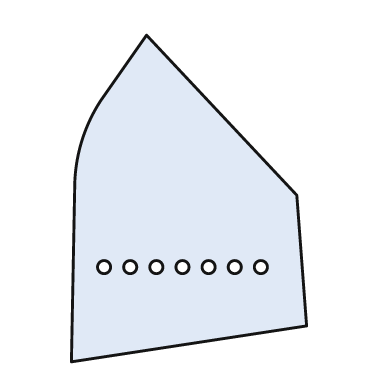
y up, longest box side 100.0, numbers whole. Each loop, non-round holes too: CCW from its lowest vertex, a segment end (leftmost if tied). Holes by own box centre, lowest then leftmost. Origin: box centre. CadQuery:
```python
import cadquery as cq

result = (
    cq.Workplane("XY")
    .moveTo(-36.0, -50.0)
    .lineTo(36.0, -39.0)
    .lineTo(33.0, 1.0)
    .lineTo(-13.0, 50.0)
    .lineTo(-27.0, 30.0)
    .threePointArc((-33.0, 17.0), (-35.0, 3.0))
    .close()
    .moveTo(-26.0, -21.0)
    .circle(2.0)
    .moveTo(-18.0, -21.0)
    .circle(2.0)
    .moveTo(-10.0, -21.0)
    .circle(2.0)
    .moveTo(-2.0, -21.0)
    .circle(2.0)
    .moveTo(6.0, -21.0)
    .circle(2.0)
    .moveTo(14.0, -21.0)
    .circle(2.0)
    .moveTo(22.0, -21.0)
    .circle(2.0)
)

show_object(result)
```